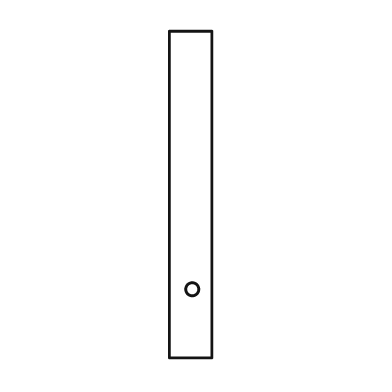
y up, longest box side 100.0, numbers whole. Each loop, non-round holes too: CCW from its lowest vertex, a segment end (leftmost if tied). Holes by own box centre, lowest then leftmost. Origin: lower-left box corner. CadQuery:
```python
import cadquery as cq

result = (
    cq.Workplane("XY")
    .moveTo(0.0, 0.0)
    .lineTo(13.0, 0.0)
    .lineTo(13.0, 100.0)
    .lineTo(0.0, 100.0)
    .close()
    .moveTo(7.0, 21.0)
    .circle(2.0)
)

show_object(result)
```